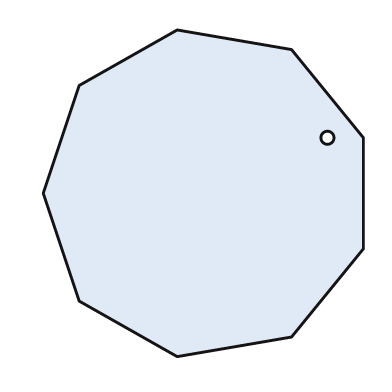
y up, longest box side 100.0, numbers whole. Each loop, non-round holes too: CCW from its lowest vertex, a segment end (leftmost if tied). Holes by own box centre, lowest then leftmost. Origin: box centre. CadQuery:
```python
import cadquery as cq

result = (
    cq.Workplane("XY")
    .moveTo(-8.0, -50.0)
    .lineTo(27.0, -44.0)
    .lineTo(49.0, -17.0)
    .lineTo(49.0, 17.0)
    .lineTo(27.0, 44.0)
    .lineTo(-8.0, 50.0)
    .lineTo(-38.0, 33.0)
    .lineTo(-49.0, 0.0)
    .lineTo(-38.0, -33.0)
    .close()
    .moveTo(38.0, 17.0)
    .circle(2.0)
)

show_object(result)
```